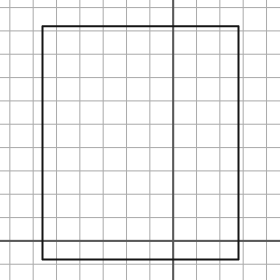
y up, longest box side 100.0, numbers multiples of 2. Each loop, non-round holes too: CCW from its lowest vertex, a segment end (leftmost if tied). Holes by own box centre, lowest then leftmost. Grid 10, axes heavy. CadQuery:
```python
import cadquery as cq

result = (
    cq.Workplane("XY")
    .moveTo(-56.0, -8.0)
    .lineTo(28.0, -8.0)
    .lineTo(28.0, 92.0)
    .lineTo(-56.0, 92.0)
    .close()
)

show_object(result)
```